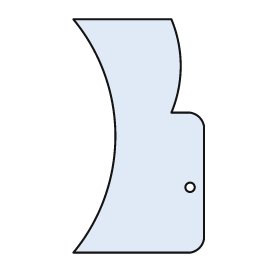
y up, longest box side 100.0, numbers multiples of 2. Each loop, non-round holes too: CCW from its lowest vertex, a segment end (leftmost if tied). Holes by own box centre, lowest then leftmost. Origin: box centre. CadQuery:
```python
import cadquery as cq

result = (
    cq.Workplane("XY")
    .moveTo(-28.0, -50.0)
    .lineTo(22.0, -50.0)
    .threePointArc((26.0, -48.0), (28.0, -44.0))
    .lineTo(28.0, 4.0)
    .threePointArc((26.0, 8.0), (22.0, 10.0))
    .lineTo(14.0, 10.0)
    .threePointArc((18.0, 30.0), (14.0, 50.0))
    .lineTo(-28.0, 50.0)
    .threePointArc((-10.0, 0.0), (-28.0, -50.0))
    .close()
    .moveTo(22.0, -22.0)
    .circle(2.0)
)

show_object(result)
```